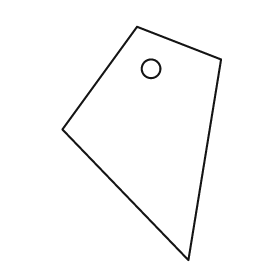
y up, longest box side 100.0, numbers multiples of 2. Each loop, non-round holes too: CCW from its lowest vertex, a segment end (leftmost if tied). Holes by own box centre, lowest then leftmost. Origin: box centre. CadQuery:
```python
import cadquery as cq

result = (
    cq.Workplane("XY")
    .moveTo(20.0, -50.0)
    .lineTo(34.0, 36.0)
    .lineTo(-2.0, 50.0)
    .lineTo(-34.0, 6.0)
    .close()
    .moveTo(4.0, 32.0)
    .circle(4.0)
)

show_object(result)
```